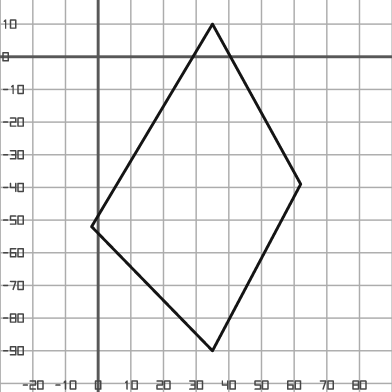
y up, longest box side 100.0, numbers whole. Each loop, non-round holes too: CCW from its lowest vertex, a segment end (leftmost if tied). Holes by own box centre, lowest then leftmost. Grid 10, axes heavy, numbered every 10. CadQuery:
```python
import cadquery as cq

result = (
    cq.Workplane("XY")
    .moveTo(35.0, -90.0)
    .lineTo(62.0, -39.0)
    .lineTo(35.0, 10.0)
    .lineTo(-2.0, -52.0)
    .close()
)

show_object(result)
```